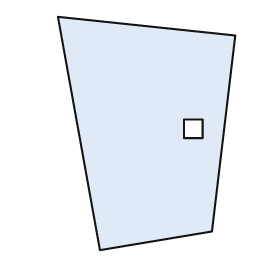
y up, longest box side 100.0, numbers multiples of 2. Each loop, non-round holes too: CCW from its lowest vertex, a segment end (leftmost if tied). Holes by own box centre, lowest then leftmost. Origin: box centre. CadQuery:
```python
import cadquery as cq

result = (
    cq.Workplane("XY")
    .moveTo(-20.0, -50.0)
    .lineTo(28.0, -42.0)
    .lineTo(38.0, 42.0)
    .lineTo(-38.0, 50.0)
    .close()
    .moveTo(16.0, -2.0)
    .lineTo(24.0, -2.0)
    .lineTo(24.0, 6.0)
    .lineTo(16.0, 6.0)
    .close()
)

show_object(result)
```